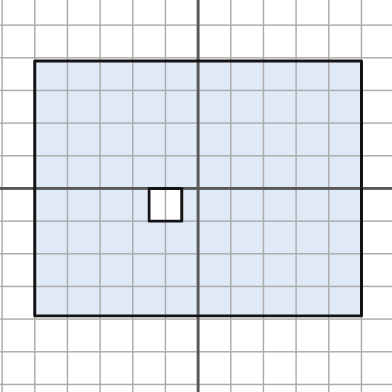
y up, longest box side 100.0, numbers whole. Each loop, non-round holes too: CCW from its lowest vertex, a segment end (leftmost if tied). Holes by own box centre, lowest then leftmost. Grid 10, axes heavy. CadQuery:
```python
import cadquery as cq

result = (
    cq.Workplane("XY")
    .moveTo(-50.0, -39.0)
    .lineTo(50.0, -39.0)
    .lineTo(50.0, 39.0)
    .lineTo(-50.0, 39.0)
    .close()
    .moveTo(-15.0, -10.0)
    .lineTo(-5.0, -10.0)
    .lineTo(-5.0, 0.0)
    .lineTo(-15.0, 0.0)
    .close()
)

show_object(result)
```